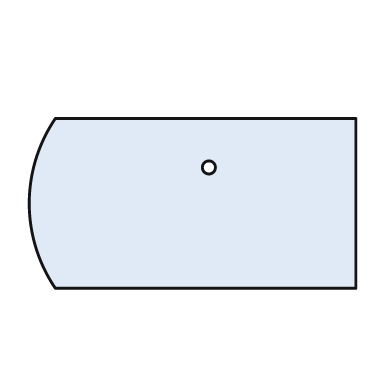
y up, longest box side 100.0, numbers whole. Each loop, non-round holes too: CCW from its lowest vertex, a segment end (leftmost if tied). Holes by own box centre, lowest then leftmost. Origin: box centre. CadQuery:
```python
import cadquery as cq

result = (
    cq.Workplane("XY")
    .moveTo(-42.0, -26.0)
    .lineTo(50.0, -26.0)
    .lineTo(50.0, 26.0)
    .lineTo(-42.0, 26.0)
    .threePointArc((-50.0, 0.0), (-42.0, -26.0))
    .close()
    .moveTo(5.0, 11.0)
    .circle(2.0)
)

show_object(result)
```